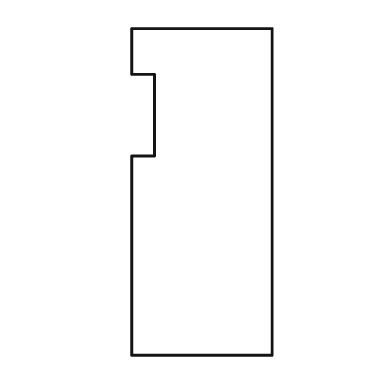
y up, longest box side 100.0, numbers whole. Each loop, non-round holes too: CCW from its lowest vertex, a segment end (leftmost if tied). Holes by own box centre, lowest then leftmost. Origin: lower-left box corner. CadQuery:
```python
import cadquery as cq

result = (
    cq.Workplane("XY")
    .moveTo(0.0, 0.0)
    .lineTo(43.0, 0.0)
    .lineTo(43.0, 100.0)
    .lineTo(0.0, 100.0)
    .lineTo(0.0, 86.0)
    .lineTo(7.0, 86.0)
    .lineTo(7.0, 61.0)
    .lineTo(0.0, 61.0)
    .close()
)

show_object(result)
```